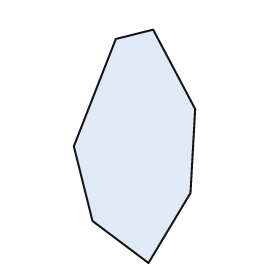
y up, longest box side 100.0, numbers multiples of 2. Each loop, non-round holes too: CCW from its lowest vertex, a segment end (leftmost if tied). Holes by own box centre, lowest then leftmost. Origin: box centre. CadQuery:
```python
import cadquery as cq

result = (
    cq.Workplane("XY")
    .moveTo(6.0, -50.0)
    .lineTo(24.0, -20.0)
    .lineTo(26.0, 16.0)
    .lineTo(8.0, 50.0)
    .lineTo(-8.0, 46.0)
    .lineTo(-26.0, 0.0)
    .lineTo(-18.0, -32.0)
    .close()
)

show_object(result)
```